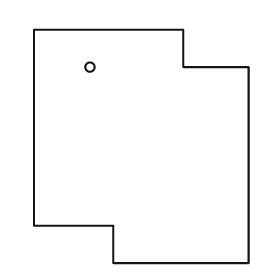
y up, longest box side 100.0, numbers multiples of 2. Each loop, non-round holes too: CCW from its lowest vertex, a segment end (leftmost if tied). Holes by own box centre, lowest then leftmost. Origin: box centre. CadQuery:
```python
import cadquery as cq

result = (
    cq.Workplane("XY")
    .moveTo(-12.0, -50.0)
    .lineTo(46.0, -50.0)
    .lineTo(46.0, 34.0)
    .lineTo(18.0, 34.0)
    .lineTo(18.0, 50.0)
    .lineTo(-46.0, 50.0)
    .lineTo(-46.0, -34.0)
    .lineTo(-12.0, -34.0)
    .close()
    .moveTo(-22.0, 34.0)
    .circle(2.0)
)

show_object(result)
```